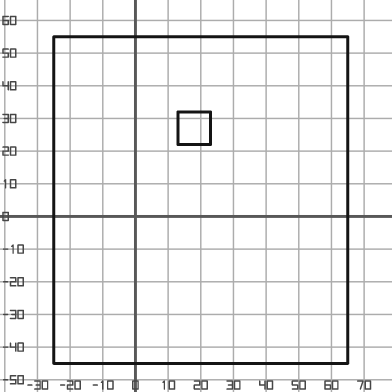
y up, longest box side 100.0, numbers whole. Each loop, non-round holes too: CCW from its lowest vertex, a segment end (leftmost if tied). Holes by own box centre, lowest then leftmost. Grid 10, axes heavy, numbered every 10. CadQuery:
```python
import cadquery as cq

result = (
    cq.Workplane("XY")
    .moveTo(-25.0, -45.0)
    .lineTo(65.0, -45.0)
    .lineTo(65.0, 55.0)
    .lineTo(-25.0, 55.0)
    .close()
    .moveTo(13.0, 22.0)
    .lineTo(23.0, 22.0)
    .lineTo(23.0, 32.0)
    .lineTo(13.0, 32.0)
    .close()
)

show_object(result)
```